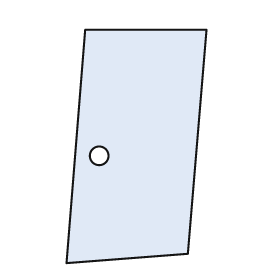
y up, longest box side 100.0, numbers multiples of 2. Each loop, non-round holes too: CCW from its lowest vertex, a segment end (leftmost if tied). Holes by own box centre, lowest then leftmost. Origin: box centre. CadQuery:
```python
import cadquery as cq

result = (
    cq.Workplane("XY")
    .moveTo(-30.0, -50.0)
    .lineTo(22.0, -46.0)
    .lineTo(30.0, 50.0)
    .lineTo(-22.0, 50.0)
    .close()
    .moveTo(-16.0, -4.0)
    .circle(4.0)
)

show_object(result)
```